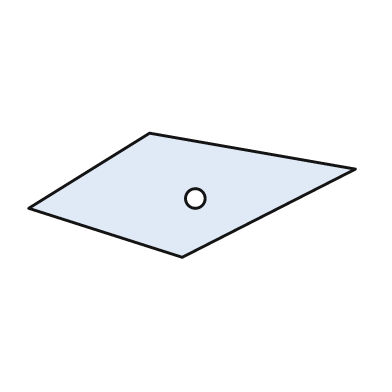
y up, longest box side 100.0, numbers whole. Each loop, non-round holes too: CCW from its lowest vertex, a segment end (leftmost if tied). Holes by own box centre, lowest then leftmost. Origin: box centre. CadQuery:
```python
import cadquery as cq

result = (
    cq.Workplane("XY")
    .moveTo(-3.0, -19.0)
    .lineTo(50.0, 8.0)
    .lineTo(-13.0, 19.0)
    .lineTo(-50.0, -4.0)
    .close()
    .moveTo(1.0, -1.0)
    .circle(3.0)
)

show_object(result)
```